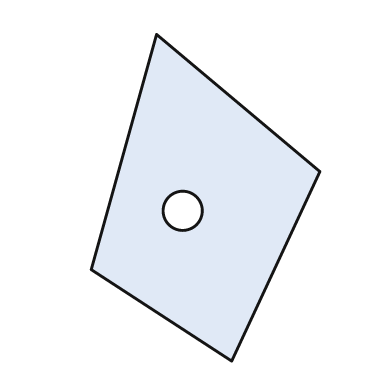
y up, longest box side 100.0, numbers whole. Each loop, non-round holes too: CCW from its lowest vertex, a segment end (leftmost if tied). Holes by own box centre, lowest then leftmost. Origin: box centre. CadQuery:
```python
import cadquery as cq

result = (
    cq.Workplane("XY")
    .moveTo(8.0, -50.0)
    .lineTo(35.0, 8.0)
    .lineTo(-15.0, 50.0)
    .lineTo(-35.0, -22.0)
    .close()
    .moveTo(-7.0, -4.0)
    .circle(6.0)
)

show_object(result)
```